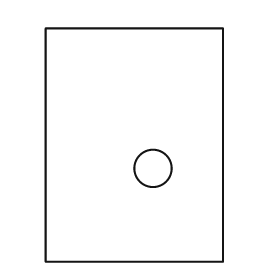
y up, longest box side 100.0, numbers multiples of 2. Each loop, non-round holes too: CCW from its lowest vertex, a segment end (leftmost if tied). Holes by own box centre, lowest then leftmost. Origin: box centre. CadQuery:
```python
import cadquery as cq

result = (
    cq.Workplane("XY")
    .moveTo(-38.0, -50.0)
    .lineTo(38.0, -50.0)
    .lineTo(38.0, 50.0)
    .lineTo(-38.0, 50.0)
    .close()
    .moveTo(8.0, -10.0)
    .circle(8.0)
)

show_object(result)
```